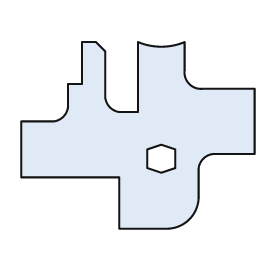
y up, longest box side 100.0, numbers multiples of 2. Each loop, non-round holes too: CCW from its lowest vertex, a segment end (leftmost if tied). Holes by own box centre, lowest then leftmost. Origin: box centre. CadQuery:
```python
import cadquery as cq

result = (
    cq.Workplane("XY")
    .moveTo(-8.0, -40.0)
    .lineTo(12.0, -40.0)
    .threePointArc((22.0, -36.0), (26.0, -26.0))
    .lineTo(26.0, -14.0)
    .threePointArc((28.0, -10.0), (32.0, -8.0))
    .lineTo(50.0, -8.0)
    .lineTo(50.0, 20.0)
    .lineTo(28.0, 20.0)
    .threePointArc((22.0, 22.0), (20.0, 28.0))
    .lineTo(20.0, 40.0)
    .threePointArc((10.0, 38.0), (0.0, 40.0))
    .lineTo(0.0, 10.0)
    .lineTo(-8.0, 10.0)
    .threePointArc((-12.0, 12.0), (-14.0, 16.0))
    .lineTo(-14.0, 36.0)
    .lineTo(-18.0, 40.0)
    .lineTo(-24.0, 40.0)
    .lineTo(-24.0, 22.0)
    .lineTo(-30.0, 22.0)
    .lineTo(-30.0, 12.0)
    .threePointArc((-32.0, 8.0), (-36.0, 6.0))
    .lineTo(-50.0, 6.0)
    .lineTo(-50.0, -18.0)
    .lineTo(-8.0, -18.0)
    .close()
    .moveTo(10.0, -16.0)
    .lineTo(16.0, -14.0)
    .lineTo(16.0, -6.0)
    .lineTo(10.0, -4.0)
    .lineTo(4.0, -6.0)
    .lineTo(4.0, -14.0)
    .close()
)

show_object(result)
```